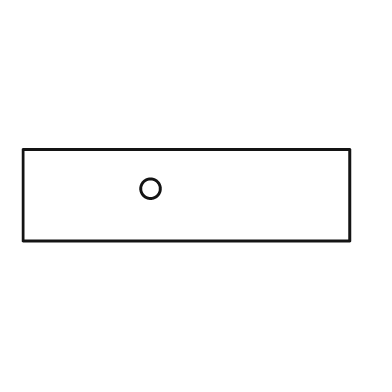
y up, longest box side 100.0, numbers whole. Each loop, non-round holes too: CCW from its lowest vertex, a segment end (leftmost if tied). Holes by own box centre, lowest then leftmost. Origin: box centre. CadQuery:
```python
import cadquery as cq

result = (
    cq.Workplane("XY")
    .moveTo(-50.0, -14.0)
    .lineTo(50.0, -14.0)
    .lineTo(50.0, 14.0)
    .lineTo(-50.0, 14.0)
    .close()
    .moveTo(-11.0, 2.0)
    .circle(3.0)
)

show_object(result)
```